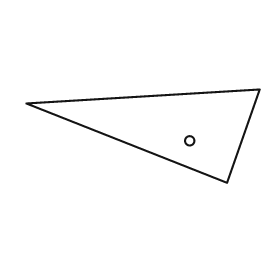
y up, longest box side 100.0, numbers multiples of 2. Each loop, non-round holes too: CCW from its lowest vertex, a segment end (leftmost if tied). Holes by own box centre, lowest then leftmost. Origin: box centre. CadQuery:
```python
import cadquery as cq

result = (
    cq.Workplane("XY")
    .moveTo(36.0, -20.0)
    .lineTo(50.0, 20.0)
    .lineTo(-50.0, 14.0)
    .close()
    .moveTo(20.0, -2.0)
    .circle(2.0)
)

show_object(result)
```